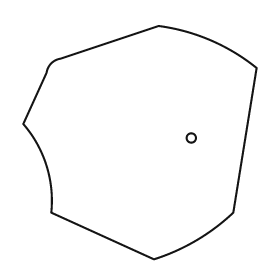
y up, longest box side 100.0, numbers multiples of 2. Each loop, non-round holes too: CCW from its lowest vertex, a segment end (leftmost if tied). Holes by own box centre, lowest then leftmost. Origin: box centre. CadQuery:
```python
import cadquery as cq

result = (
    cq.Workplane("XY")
    .moveTo(6.0, -50.0)
    .threePointArc((24.0, -42.0), (40.0, -30.0))
    .lineTo(50.0, 32.0)
    .threePointArc((30.0, 44.0), (8.0, 50.0))
    .lineTo(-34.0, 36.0)
    .threePointArc((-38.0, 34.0), (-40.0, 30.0))
    .lineTo(-50.0, 8.0)
    .threePointArc((-40.0, -10.0), (-38.0, -30.0))
    .close()
    .moveTo(22.0, 2.0)
    .circle(2.0)
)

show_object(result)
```